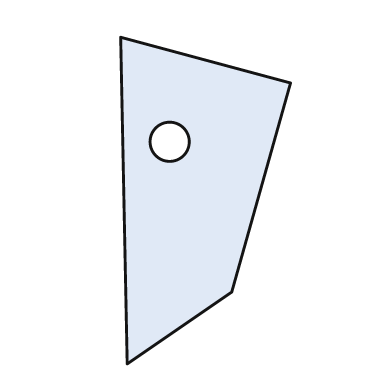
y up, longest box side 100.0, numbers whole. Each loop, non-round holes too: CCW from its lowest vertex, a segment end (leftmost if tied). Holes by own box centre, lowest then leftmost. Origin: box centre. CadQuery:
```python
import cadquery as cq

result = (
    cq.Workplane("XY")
    .moveTo(-24.0, -50.0)
    .lineTo(8.0, -28.0)
    .lineTo(26.0, 36.0)
    .lineTo(-26.0, 50.0)
    .close()
    .moveTo(-11.0, 18.0)
    .circle(6.0)
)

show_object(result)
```